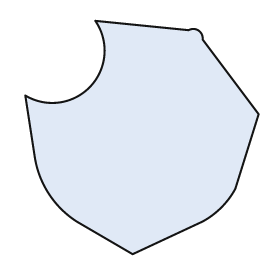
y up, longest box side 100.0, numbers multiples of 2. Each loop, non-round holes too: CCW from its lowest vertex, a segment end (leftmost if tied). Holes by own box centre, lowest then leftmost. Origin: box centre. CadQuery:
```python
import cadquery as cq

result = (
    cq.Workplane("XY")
    .moveTo(-4.0, -50.0)
    .lineTo(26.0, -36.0)
    .threePointArc((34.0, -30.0), (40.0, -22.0))
    .lineTo(50.0, 10.0)
    .lineTo(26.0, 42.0)
    .threePointArc((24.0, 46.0), (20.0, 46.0))
    .lineTo(-20.0, 50.0)
    .threePointArc((-22.0, 22.0), (-50.0, 18.0))
    .lineTo(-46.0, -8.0)
    .threePointArc((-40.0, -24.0), (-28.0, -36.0))
    .close()
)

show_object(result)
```